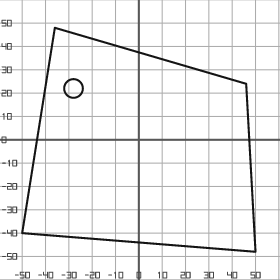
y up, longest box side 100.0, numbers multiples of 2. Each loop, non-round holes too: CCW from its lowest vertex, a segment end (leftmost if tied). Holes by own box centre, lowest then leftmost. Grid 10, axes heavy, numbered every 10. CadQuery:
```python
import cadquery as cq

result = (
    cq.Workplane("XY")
    .moveTo(50.0, -48.0)
    .lineTo(46.0, 24.0)
    .lineTo(-36.0, 48.0)
    .lineTo(-50.0, -40.0)
    .close()
    .moveTo(-28.0, 22.0)
    .circle(4.0)
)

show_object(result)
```